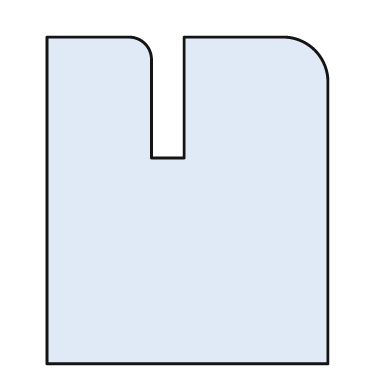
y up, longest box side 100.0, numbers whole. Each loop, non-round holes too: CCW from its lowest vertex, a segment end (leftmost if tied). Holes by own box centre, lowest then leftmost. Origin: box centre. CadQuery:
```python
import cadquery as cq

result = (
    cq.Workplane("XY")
    .moveTo(-43.0, -50.0)
    .lineTo(43.0, -50.0)
    .lineTo(43.0, 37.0)
    .threePointArc((39.0, 46.0), (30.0, 50.0))
    .lineTo(-1.0, 50.0)
    .lineTo(-1.0, 13.0)
    .lineTo(-11.0, 13.0)
    .lineTo(-11.0, 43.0)
    .threePointArc((-13.0, 48.0), (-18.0, 50.0))
    .lineTo(-43.0, 50.0)
    .close()
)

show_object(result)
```